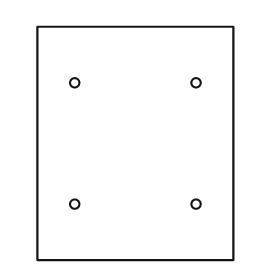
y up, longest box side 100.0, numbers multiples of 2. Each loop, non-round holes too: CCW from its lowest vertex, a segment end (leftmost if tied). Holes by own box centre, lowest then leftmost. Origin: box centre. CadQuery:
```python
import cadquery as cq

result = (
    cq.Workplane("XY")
    .moveTo(-42.0, -50.0)
    .lineTo(42.0, -50.0)
    .lineTo(42.0, 50.0)
    .lineTo(-42.0, 50.0)
    .close()
    .moveTo(-26.0, -26.0)
    .circle(2.0)
    .moveTo(26.0, -26.0)
    .circle(2.0)
    .moveTo(-26.0, 26.0)
    .circle(2.0)
    .moveTo(26.0, 26.0)
    .circle(2.0)
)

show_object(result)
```